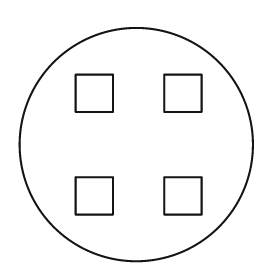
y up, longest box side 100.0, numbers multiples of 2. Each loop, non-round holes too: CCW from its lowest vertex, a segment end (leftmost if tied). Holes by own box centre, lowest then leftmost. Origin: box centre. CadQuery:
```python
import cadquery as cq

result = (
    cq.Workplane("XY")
    .moveTo(0.0, 0.0)
    .circle(50.0)
    .moveTo(-26.0, -30.0)
    .lineTo(-10.0, -30.0)
    .lineTo(-10.0, -14.0)
    .lineTo(-26.0, -14.0)
    .close()
    .moveTo(12.0, -30.0)
    .lineTo(28.0, -30.0)
    .lineTo(28.0, -14.0)
    .lineTo(12.0, -14.0)
    .close()
    .moveTo(-26.0, 14.0)
    .lineTo(-10.0, 14.0)
    .lineTo(-10.0, 30.0)
    .lineTo(-26.0, 30.0)
    .close()
    .moveTo(12.0, 14.0)
    .lineTo(28.0, 14.0)
    .lineTo(28.0, 30.0)
    .lineTo(12.0, 30.0)
    .close()
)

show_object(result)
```